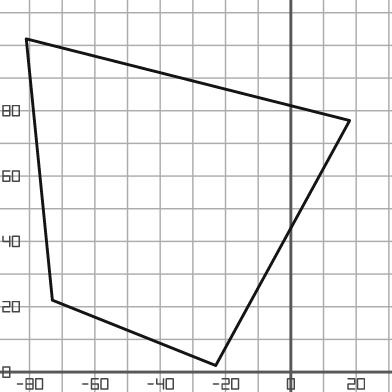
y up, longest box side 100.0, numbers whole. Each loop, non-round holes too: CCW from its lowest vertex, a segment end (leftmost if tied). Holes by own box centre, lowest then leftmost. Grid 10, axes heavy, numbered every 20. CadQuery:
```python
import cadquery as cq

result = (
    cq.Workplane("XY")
    .moveTo(-23.0, 2.0)
    .lineTo(18.0, 77.0)
    .lineTo(-81.0, 102.0)
    .lineTo(-73.0, 22.0)
    .close()
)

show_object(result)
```